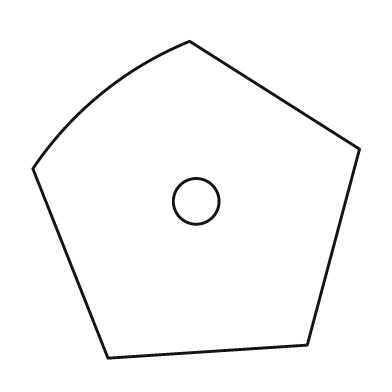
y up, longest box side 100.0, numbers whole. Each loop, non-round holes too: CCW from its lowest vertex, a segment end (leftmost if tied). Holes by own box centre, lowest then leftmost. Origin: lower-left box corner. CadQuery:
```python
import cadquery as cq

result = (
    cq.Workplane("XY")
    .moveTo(23.0, 0.0)
    .lineTo(84.0, 4.0)
    .lineTo(100.0, 64.0)
    .lineTo(48.0, 97.0)
    .threePointArc((21.0, 81.0), (0.0, 58.0))
    .close()
    .moveTo(50.0, 48.0)
    .circle(7.0)
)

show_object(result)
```